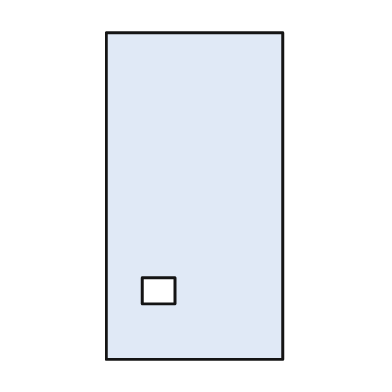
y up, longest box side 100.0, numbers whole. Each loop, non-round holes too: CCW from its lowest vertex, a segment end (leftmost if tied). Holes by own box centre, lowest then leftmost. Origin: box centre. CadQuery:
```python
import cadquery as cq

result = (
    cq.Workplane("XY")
    .moveTo(-27.0, -50.0)
    .lineTo(27.0, -50.0)
    .lineTo(27.0, 50.0)
    .lineTo(-27.0, 50.0)
    .close()
    .moveTo(-16.0, -33.0)
    .lineTo(-6.0, -33.0)
    .lineTo(-6.0, -25.0)
    .lineTo(-16.0, -25.0)
    .close()
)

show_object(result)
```